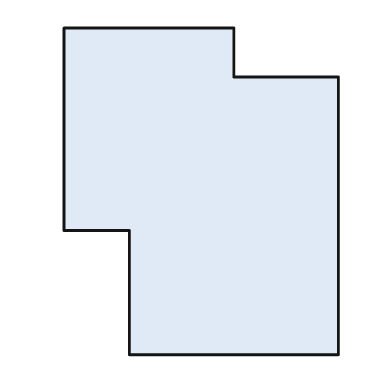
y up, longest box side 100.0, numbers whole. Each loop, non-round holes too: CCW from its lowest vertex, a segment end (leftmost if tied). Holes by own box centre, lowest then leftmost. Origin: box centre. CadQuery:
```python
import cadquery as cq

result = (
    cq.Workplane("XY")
    .moveTo(-22.0, -50.0)
    .lineTo(42.0, -50.0)
    .lineTo(42.0, 35.0)
    .lineTo(10.0, 35.0)
    .lineTo(10.0, 50.0)
    .lineTo(-42.0, 50.0)
    .lineTo(-42.0, -12.0)
    .lineTo(-22.0, -12.0)
    .close()
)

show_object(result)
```